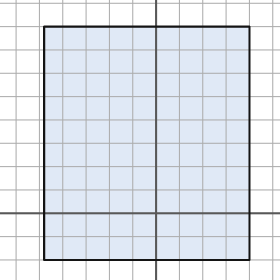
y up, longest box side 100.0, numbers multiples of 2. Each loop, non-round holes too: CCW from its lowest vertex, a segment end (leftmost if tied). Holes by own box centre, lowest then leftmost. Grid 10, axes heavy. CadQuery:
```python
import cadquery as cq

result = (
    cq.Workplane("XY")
    .moveTo(-48.0, -20.0)
    .lineTo(40.0, -20.0)
    .lineTo(40.0, 80.0)
    .lineTo(-48.0, 80.0)
    .close()
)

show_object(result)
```